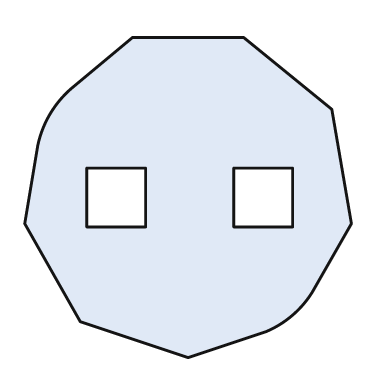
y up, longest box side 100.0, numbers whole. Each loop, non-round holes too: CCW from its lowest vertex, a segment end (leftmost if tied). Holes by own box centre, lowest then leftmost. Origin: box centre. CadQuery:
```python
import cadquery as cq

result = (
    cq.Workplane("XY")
    .moveTo(0.0, -49.0)
    .lineTo(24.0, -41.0)
    .threePointArc((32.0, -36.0), (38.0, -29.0))
    .lineTo(50.0, -8.0)
    .lineTo(44.0, 27.0)
    .lineTo(17.0, 49.0)
    .lineTo(-17.0, 49.0)
    .lineTo(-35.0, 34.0)
    .threePointArc((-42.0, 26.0), (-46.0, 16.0))
    .lineTo(-50.0, -8.0)
    .lineTo(-33.0, -38.0)
    .close()
    .moveTo(-31.0, -9.0)
    .lineTo(-13.0, -9.0)
    .lineTo(-13.0, 9.0)
    .lineTo(-31.0, 9.0)
    .close()
    .moveTo(14.0, -9.0)
    .lineTo(32.0, -9.0)
    .lineTo(32.0, 9.0)
    .lineTo(14.0, 9.0)
    .close()
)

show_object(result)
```